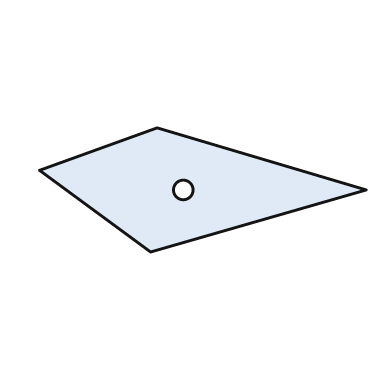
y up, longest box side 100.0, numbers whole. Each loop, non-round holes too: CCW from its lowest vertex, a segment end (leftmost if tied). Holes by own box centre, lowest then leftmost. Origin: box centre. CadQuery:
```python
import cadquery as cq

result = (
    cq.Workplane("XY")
    .moveTo(-16.0, -19.0)
    .lineTo(50.0, 0.0)
    .lineTo(-14.0, 19.0)
    .lineTo(-50.0, 6.0)
    .close()
    .moveTo(-6.0, 0.0)
    .circle(3.0)
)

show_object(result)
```